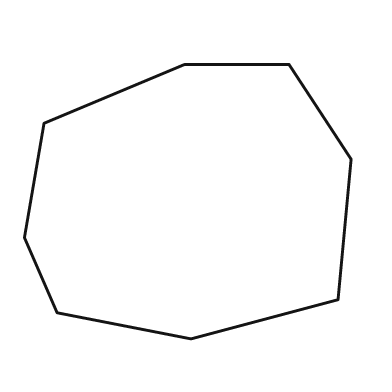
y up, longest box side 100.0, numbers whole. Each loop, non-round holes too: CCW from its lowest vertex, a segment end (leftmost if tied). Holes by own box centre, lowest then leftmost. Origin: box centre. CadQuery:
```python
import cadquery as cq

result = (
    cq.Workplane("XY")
    .moveTo(1.0, -42.0)
    .lineTo(46.0, -30.0)
    .lineTo(50.0, 13.0)
    .lineTo(31.0, 42.0)
    .lineTo(-1.0, 42.0)
    .lineTo(-44.0, 24.0)
    .lineTo(-50.0, -11.0)
    .lineTo(-40.0, -34.0)
    .close()
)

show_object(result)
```